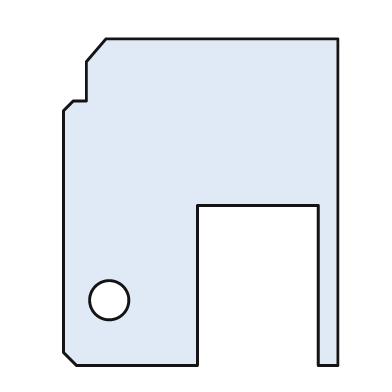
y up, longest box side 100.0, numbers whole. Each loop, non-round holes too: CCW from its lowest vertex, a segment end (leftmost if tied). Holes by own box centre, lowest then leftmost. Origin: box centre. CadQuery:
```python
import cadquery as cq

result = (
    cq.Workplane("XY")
    .moveTo(-38.0, -50.0)
    .lineTo(-1.0, -50.0)
    .lineTo(-1.0, -1.0)
    .lineTo(36.0, -1.0)
    .lineTo(36.0, -50.0)
    .lineTo(42.0, -50.0)
    .lineTo(42.0, 50.0)
    .lineTo(-29.0, 50.0)
    .lineTo(-35.0, 43.0)
    .lineTo(-35.0, 31.0)
    .lineTo(-39.0, 31.0)
    .lineTo(-42.0, 28.0)
    .lineTo(-42.0, -46.0)
    .close()
    .moveTo(-28.0, -30.0)
    .circle(6.0)
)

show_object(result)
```